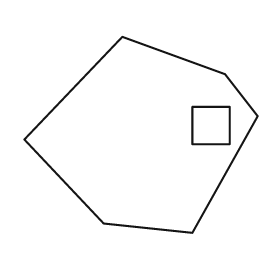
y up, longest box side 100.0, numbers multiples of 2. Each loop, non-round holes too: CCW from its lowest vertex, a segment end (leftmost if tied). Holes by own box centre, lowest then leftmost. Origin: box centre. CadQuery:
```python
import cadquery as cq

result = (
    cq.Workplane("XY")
    .moveTo(22.0, -42.0)
    .lineTo(50.0, 8.0)
    .lineTo(36.0, 26.0)
    .lineTo(-8.0, 42.0)
    .lineTo(-50.0, -2.0)
    .lineTo(-16.0, -38.0)
    .close()
    .moveTo(22.0, -4.0)
    .lineTo(38.0, -4.0)
    .lineTo(38.0, 12.0)
    .lineTo(22.0, 12.0)
    .close()
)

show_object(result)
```